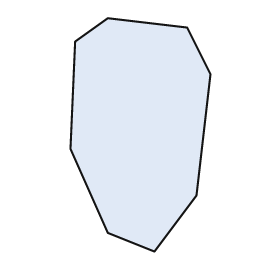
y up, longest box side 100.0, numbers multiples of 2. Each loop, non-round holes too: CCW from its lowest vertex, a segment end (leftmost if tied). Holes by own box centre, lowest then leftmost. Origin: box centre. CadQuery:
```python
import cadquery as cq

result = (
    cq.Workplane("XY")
    .moveTo(6.0, -50.0)
    .lineTo(24.0, -26.0)
    .lineTo(30.0, 26.0)
    .lineTo(20.0, 46.0)
    .lineTo(-14.0, 50.0)
    .lineTo(-28.0, 40.0)
    .lineTo(-30.0, -6.0)
    .lineTo(-14.0, -42.0)
    .close()
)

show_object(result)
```